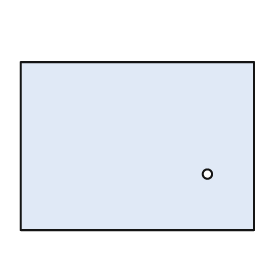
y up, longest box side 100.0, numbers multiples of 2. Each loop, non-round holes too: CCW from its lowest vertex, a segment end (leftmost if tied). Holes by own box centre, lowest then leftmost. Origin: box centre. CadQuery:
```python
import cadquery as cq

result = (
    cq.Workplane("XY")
    .moveTo(-50.0, -36.0)
    .lineTo(50.0, -36.0)
    .lineTo(50.0, 36.0)
    .lineTo(-50.0, 36.0)
    .close()
    .moveTo(30.0, -12.0)
    .circle(2.0)
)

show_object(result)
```